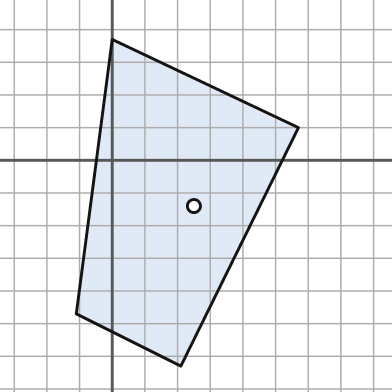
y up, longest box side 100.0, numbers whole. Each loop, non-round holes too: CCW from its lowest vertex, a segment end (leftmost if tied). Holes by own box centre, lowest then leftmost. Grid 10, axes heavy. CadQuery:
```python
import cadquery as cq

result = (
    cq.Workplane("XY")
    .moveTo(21.0, -63.0)
    .lineTo(57.0, 10.0)
    .lineTo(0.0, 37.0)
    .lineTo(-11.0, -47.0)
    .close()
    .moveTo(25.0, -14.0)
    .circle(2.0)
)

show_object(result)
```